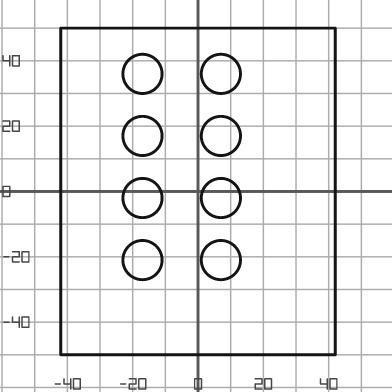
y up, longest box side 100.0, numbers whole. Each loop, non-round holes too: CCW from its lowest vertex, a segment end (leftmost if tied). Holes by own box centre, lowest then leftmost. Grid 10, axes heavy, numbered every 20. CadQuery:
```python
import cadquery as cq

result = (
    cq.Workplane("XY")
    .moveTo(-42.0, -50.0)
    .lineTo(42.0, -50.0)
    .lineTo(42.0, 50.0)
    .lineTo(-42.0, 50.0)
    .close()
    .moveTo(-17.0, -21.0)
    .circle(6.0)
    .moveTo(7.0, -21.0)
    .circle(6.0)
    .moveTo(-17.0, -2.0)
    .circle(6.0)
    .moveTo(7.0, -2.0)
    .circle(6.0)
    .moveTo(-17.0, 17.0)
    .circle(6.0)
    .moveTo(7.0, 17.0)
    .circle(6.0)
    .moveTo(-17.0, 36.0)
    .circle(6.0)
    .moveTo(7.0, 36.0)
    .circle(6.0)
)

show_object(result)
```